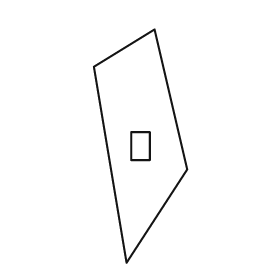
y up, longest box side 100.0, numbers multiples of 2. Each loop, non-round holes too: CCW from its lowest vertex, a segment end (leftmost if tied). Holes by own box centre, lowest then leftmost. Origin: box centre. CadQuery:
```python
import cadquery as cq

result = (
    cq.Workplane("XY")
    .moveTo(-6.0, -50.0)
    .lineTo(20.0, -10.0)
    .lineTo(6.0, 50.0)
    .lineTo(-20.0, 34.0)
    .close()
    .moveTo(-4.0, -6.0)
    .lineTo(4.0, -6.0)
    .lineTo(4.0, 6.0)
    .lineTo(-4.0, 6.0)
    .close()
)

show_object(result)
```